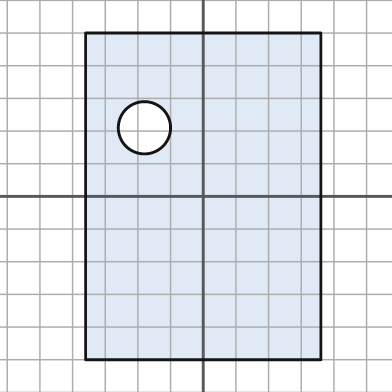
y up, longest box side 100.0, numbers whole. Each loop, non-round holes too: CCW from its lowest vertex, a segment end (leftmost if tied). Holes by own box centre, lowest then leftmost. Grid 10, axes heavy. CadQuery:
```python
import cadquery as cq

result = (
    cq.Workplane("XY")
    .moveTo(-36.0, -50.0)
    .lineTo(36.0, -50.0)
    .lineTo(36.0, 50.0)
    .lineTo(-36.0, 50.0)
    .close()
    .moveTo(-18.0, 21.0)
    .circle(8.0)
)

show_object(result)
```